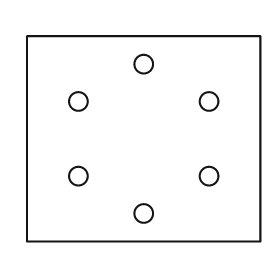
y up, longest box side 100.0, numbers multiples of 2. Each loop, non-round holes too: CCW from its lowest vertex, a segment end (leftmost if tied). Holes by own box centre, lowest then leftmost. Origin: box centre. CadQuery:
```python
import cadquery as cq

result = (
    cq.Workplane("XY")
    .moveTo(-50.0, -44.0)
    .lineTo(50.0, -44.0)
    .lineTo(50.0, 44.0)
    .lineTo(-50.0, 44.0)
    .close()
    .moveTo(0.0, -32.0)
    .circle(4.0)
    .moveTo(-28.0, -16.0)
    .circle(4.0)
    .moveTo(28.0, -16.0)
    .circle(4.0)
    .moveTo(-28.0, 16.0)
    .circle(4.0)
    .moveTo(28.0, 16.0)
    .circle(4.0)
    .moveTo(0.0, 32.0)
    .circle(4.0)
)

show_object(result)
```